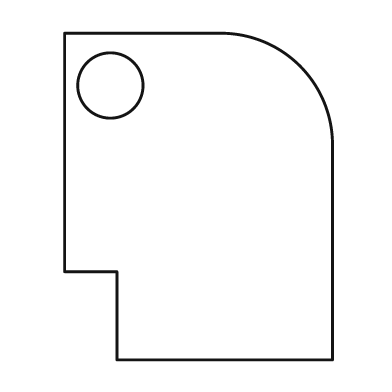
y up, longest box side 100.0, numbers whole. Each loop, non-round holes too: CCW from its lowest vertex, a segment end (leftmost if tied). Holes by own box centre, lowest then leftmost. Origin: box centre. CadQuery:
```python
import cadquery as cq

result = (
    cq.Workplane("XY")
    .moveTo(-25.0, -50.0)
    .lineTo(41.0, -50.0)
    .lineTo(41.0, 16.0)
    .threePointArc((31.0, 40.0), (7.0, 50.0))
    .lineTo(-41.0, 50.0)
    .lineTo(-41.0, -23.0)
    .lineTo(-25.0, -23.0)
    .close()
    .moveTo(-27.0, 34.0)
    .circle(10.0)
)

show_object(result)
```